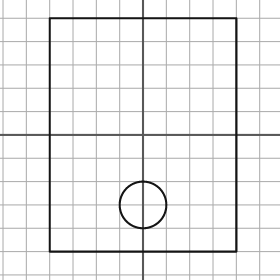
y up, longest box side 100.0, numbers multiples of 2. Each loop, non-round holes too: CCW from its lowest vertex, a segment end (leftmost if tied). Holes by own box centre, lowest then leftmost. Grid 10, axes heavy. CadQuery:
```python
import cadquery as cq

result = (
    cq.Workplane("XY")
    .moveTo(-40.0, -50.0)
    .lineTo(40.0, -50.0)
    .lineTo(40.0, 50.0)
    .lineTo(-40.0, 50.0)
    .close()
    .moveTo(0.0, -30.0)
    .circle(10.0)
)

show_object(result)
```